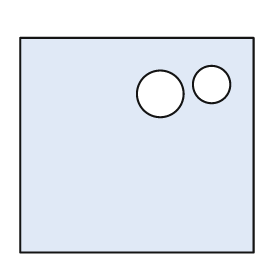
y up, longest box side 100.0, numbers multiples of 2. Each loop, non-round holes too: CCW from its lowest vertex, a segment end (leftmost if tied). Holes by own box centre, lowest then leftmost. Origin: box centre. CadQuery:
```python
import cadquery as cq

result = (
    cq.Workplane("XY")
    .moveTo(-50.0, -46.0)
    .lineTo(50.0, -46.0)
    .lineTo(50.0, 46.0)
    .lineTo(-50.0, 46.0)
    .close()
    .moveTo(10.0, 22.0)
    .circle(10.0)
    .moveTo(32.0, 26.0)
    .circle(8.0)
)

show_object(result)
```